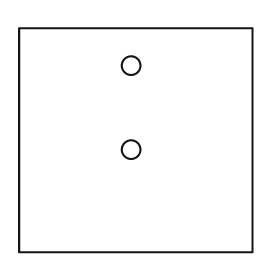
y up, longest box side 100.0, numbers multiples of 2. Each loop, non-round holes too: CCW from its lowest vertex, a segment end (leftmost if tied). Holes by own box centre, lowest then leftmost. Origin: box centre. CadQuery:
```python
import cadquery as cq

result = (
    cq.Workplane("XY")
    .moveTo(-50.0, -48.0)
    .lineTo(50.0, -48.0)
    .lineTo(50.0, 48.0)
    .lineTo(-50.0, 48.0)
    .close()
    .moveTo(-2.0, -4.0)
    .circle(4.0)
    .moveTo(-2.0, 32.0)
    .circle(4.0)
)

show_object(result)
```